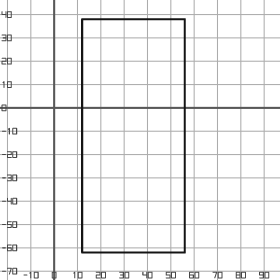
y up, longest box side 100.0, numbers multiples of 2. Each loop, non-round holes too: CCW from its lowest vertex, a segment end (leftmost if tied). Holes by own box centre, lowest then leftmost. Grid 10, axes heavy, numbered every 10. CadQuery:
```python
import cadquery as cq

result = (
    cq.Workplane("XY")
    .moveTo(12.0, -62.0)
    .lineTo(56.0, -62.0)
    .lineTo(56.0, 38.0)
    .lineTo(12.0, 38.0)
    .close()
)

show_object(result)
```